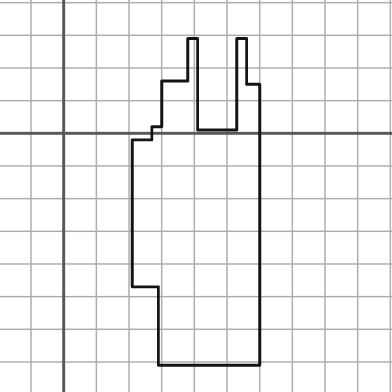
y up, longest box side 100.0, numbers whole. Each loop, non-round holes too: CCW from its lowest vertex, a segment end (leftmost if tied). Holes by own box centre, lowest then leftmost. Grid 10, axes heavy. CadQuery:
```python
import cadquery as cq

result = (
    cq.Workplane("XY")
    .moveTo(29.0, -71.0)
    .lineTo(60.0, -71.0)
    .lineTo(60.0, 15.0)
    .lineTo(56.0, 15.0)
    .lineTo(56.0, 29.0)
    .lineTo(53.0, 29.0)
    .lineTo(53.0, 1.0)
    .lineTo(41.0, 1.0)
    .lineTo(41.0, 29.0)
    .lineTo(38.0, 29.0)
    .lineTo(38.0, 16.0)
    .lineTo(30.0, 16.0)
    .lineTo(30.0, 2.0)
    .lineTo(27.0, 2.0)
    .lineTo(27.0, -2.0)
    .lineTo(21.0, -2.0)
    .lineTo(21.0, -47.0)
    .lineTo(29.0, -47.0)
    .close()
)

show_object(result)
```